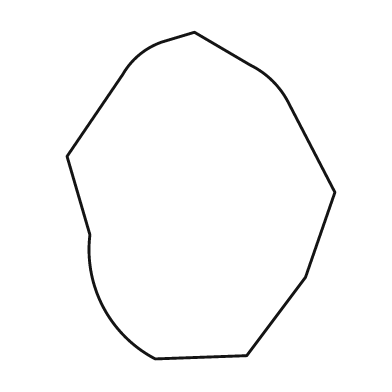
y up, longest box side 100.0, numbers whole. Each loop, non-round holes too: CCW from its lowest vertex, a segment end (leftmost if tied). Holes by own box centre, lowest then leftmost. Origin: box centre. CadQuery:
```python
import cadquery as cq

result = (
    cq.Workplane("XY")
    .moveTo(-14.0, -50.0)
    .lineTo(14.0, -49.0)
    .lineTo(32.0, -25.0)
    .lineTo(41.0, 1.0)
    .lineTo(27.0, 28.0)
    .threePointArc((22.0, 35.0), (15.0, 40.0))
    .lineTo(-2.0, 50.0)
    .lineTo(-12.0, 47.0)
    .threePointArc((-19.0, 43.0), (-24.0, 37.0))
    .lineTo(-41.0, 12.0)
    .lineTo(-34.0, -12.0)
    .threePointArc((-30.0, -34.0), (-14.0, -50.0))
    .close()
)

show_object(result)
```